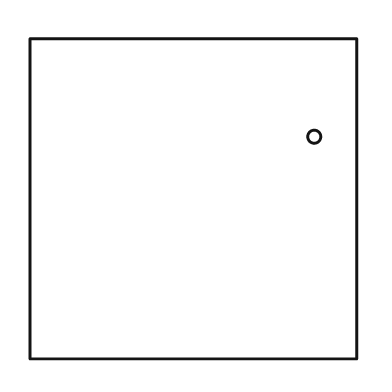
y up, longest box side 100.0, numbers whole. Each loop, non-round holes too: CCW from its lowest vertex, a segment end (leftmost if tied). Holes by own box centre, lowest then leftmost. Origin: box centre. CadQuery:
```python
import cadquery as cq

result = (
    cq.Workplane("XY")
    .moveTo(-50.0, -49.0)
    .lineTo(50.0, -49.0)
    .lineTo(50.0, 49.0)
    .lineTo(-50.0, 49.0)
    .close()
    .moveTo(37.0, 19.0)
    .circle(2.0)
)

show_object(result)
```